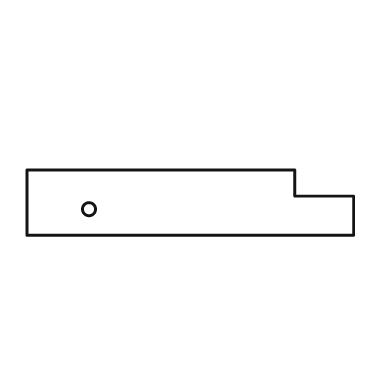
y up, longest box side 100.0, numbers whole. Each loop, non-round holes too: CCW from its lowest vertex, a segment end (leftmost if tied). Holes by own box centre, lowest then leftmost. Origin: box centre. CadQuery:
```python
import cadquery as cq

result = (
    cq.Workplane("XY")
    .moveTo(-50.0, -10.0)
    .lineTo(50.0, -10.0)
    .lineTo(50.0, 2.0)
    .lineTo(32.0, 2.0)
    .lineTo(32.0, 10.0)
    .lineTo(-50.0, 10.0)
    .close()
    .moveTo(-31.0, -2.0)
    .circle(2.0)
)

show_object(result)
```